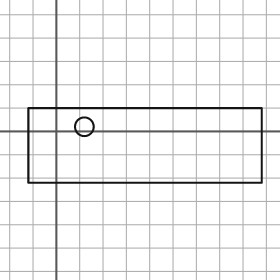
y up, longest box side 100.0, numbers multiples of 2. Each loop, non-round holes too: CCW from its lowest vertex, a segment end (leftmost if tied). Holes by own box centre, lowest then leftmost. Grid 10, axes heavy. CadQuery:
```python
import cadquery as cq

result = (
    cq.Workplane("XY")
    .moveTo(-12.0, -22.0)
    .lineTo(88.0, -22.0)
    .lineTo(88.0, 10.0)
    .lineTo(-12.0, 10.0)
    .close()
    .moveTo(12.0, 2.0)
    .circle(4.0)
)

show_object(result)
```